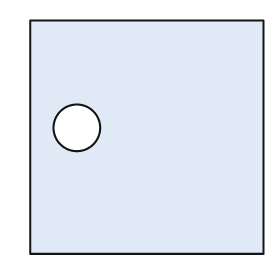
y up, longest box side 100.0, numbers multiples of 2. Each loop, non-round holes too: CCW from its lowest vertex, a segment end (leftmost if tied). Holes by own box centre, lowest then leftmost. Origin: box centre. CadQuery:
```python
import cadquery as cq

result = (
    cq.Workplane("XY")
    .moveTo(-50.0, -50.0)
    .lineTo(50.0, -50.0)
    .lineTo(50.0, 50.0)
    .lineTo(-50.0, 50.0)
    .close()
    .moveTo(-30.0, 4.0)
    .circle(10.0)
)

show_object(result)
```